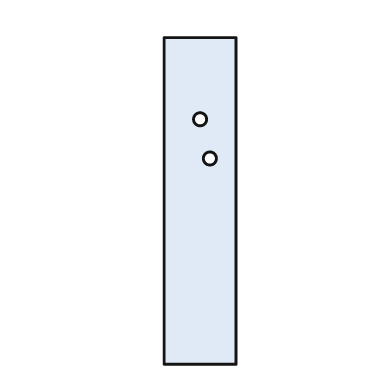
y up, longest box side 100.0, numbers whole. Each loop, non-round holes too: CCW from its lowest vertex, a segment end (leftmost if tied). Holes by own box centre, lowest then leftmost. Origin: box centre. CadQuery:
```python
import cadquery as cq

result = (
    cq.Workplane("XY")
    .moveTo(-11.0, -50.0)
    .lineTo(11.0, -50.0)
    .lineTo(11.0, 50.0)
    .lineTo(-11.0, 50.0)
    .close()
    .moveTo(3.0, 13.0)
    .circle(2.0)
    .moveTo(0.0, 25.0)
    .circle(2.0)
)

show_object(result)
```